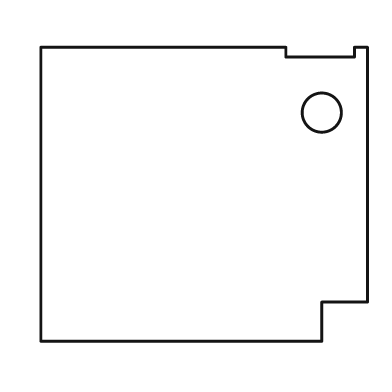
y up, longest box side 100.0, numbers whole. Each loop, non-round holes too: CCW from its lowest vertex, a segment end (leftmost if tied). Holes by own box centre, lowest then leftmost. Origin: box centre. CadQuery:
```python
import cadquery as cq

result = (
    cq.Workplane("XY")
    .moveTo(-50.0, -45.0)
    .lineTo(36.0, -45.0)
    .lineTo(36.0, -33.0)
    .lineTo(50.0, -33.0)
    .lineTo(50.0, 45.0)
    .lineTo(46.0, 45.0)
    .lineTo(46.0, 42.0)
    .lineTo(25.0, 42.0)
    .lineTo(25.0, 45.0)
    .lineTo(-50.0, 45.0)
    .close()
    .moveTo(36.0, 25.0)
    .circle(6.0)
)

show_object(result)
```